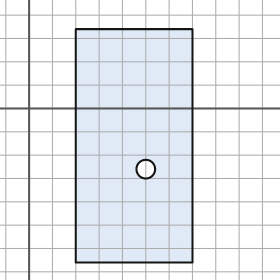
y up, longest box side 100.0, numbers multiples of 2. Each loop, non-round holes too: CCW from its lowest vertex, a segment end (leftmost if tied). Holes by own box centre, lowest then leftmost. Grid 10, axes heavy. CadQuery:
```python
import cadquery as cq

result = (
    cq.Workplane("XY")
    .moveTo(20.0, -66.0)
    .lineTo(70.0, -66.0)
    .lineTo(70.0, 34.0)
    .lineTo(20.0, 34.0)
    .close()
    .moveTo(50.0, -26.0)
    .circle(4.0)
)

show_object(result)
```